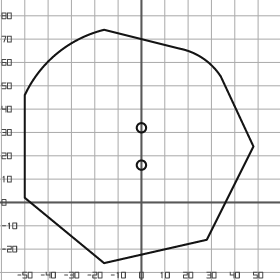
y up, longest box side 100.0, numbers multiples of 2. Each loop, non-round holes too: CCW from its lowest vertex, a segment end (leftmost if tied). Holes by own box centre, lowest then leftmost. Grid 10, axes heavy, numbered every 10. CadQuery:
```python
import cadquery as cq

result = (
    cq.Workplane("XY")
    .moveTo(-16.0, -26.0)
    .lineTo(28.0, -16.0)
    .lineTo(48.0, 24.0)
    .lineTo(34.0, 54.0)
    .threePointArc((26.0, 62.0), (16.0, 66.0))
    .lineTo(-16.0, 74.0)
    .threePointArc((-36.0, 64.0), (-50.0, 46.0))
    .lineTo(-50.0, 2.0)
    .close()
    .moveTo(0.0, 16.0)
    .circle(2.0)
    .moveTo(0.0, 32.0)
    .circle(2.0)
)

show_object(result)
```